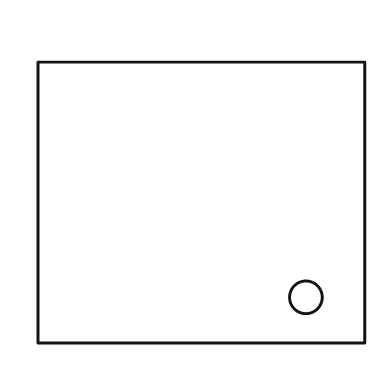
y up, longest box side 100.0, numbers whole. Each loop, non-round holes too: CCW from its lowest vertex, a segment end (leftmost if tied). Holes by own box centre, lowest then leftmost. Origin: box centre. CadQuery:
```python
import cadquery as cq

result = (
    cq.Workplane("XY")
    .moveTo(-50.0, -43.0)
    .lineTo(50.0, -43.0)
    .lineTo(50.0, 43.0)
    .lineTo(-50.0, 43.0)
    .close()
    .moveTo(32.0, -29.0)
    .circle(5.0)
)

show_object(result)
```